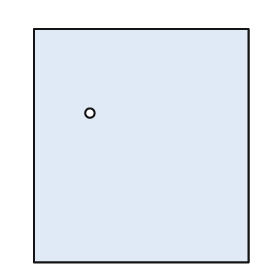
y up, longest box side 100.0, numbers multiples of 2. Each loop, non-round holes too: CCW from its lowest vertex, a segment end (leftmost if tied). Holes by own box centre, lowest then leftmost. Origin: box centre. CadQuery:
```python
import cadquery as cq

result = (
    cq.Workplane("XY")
    .moveTo(-46.0, -50.0)
    .lineTo(46.0, -50.0)
    .lineTo(46.0, 50.0)
    .lineTo(-46.0, 50.0)
    .close()
    .moveTo(-22.0, 14.0)
    .circle(2.0)
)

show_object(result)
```